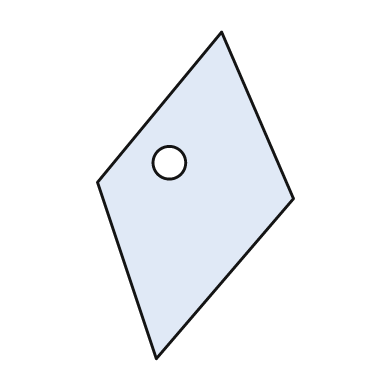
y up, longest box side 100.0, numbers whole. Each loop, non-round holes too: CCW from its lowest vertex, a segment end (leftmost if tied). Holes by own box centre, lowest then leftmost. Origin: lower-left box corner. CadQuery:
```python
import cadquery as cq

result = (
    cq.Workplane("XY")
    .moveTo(18.0, 0.0)
    .lineTo(60.0, 49.0)
    .lineTo(38.0, 100.0)
    .lineTo(0.0, 54.0)
    .close()
    .moveTo(22.0, 60.0)
    .circle(5.0)
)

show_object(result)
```